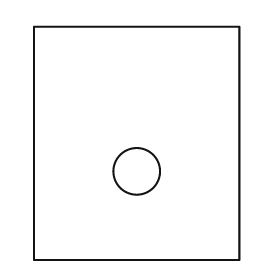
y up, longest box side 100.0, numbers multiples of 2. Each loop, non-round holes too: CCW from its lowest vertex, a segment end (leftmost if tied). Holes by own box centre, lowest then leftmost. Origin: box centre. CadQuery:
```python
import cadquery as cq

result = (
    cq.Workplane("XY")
    .moveTo(-44.0, -50.0)
    .lineTo(44.0, -50.0)
    .lineTo(44.0, 50.0)
    .lineTo(-44.0, 50.0)
    .close()
    .moveTo(0.0, -12.0)
    .circle(10.0)
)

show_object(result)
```